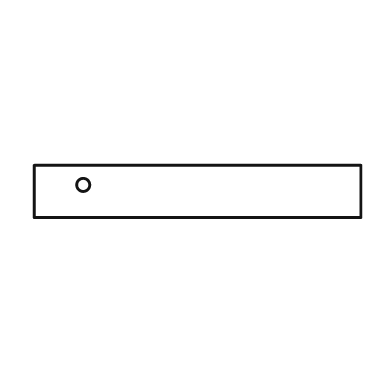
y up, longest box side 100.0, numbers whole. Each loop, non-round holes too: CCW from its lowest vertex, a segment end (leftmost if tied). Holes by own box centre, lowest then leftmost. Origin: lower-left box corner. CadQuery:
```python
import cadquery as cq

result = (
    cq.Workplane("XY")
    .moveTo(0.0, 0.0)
    .lineTo(100.0, 0.0)
    .lineTo(100.0, 16.0)
    .lineTo(0.0, 16.0)
    .close()
    .moveTo(15.0, 10.0)
    .circle(2.0)
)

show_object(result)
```